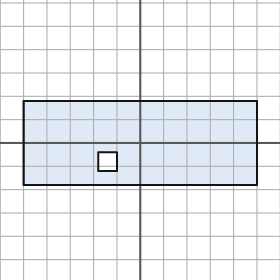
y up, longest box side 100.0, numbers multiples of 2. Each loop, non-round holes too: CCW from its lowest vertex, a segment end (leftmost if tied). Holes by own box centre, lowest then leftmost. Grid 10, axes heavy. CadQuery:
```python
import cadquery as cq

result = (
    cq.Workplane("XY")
    .moveTo(-50.0, -18.0)
    .lineTo(50.0, -18.0)
    .lineTo(50.0, 18.0)
    .lineTo(-50.0, 18.0)
    .close()
    .moveTo(-18.0, -12.0)
    .lineTo(-10.0, -12.0)
    .lineTo(-10.0, -4.0)
    .lineTo(-18.0, -4.0)
    .close()
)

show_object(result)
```